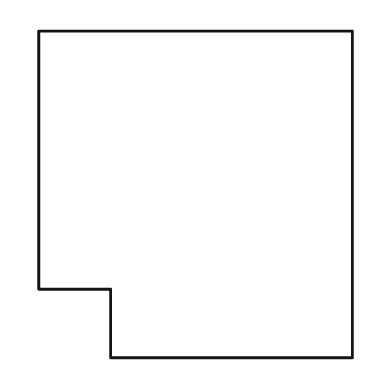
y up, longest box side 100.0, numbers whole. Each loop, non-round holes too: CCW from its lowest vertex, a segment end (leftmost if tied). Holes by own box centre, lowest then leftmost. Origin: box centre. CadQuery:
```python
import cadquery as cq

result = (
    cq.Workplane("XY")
    .moveTo(-26.0, -50.0)
    .lineTo(48.0, -50.0)
    .lineTo(48.0, 50.0)
    .lineTo(-48.0, 50.0)
    .lineTo(-48.0, -29.0)
    .lineTo(-26.0, -29.0)
    .close()
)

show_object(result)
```